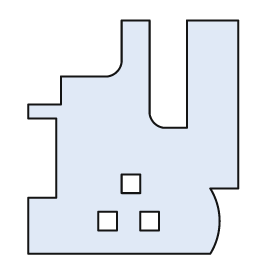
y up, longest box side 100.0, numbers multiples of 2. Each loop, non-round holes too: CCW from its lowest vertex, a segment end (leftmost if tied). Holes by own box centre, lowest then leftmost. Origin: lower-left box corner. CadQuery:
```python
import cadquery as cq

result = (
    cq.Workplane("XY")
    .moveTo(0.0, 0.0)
    .lineTo(78.0, 0.0)
    .threePointArc((82.0, 14.0), (78.0, 28.0))
    .lineTo(90.0, 28.0)
    .lineTo(90.0, 100.0)
    .lineTo(68.0, 100.0)
    .lineTo(68.0, 54.0)
    .lineTo(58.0, 54.0)
    .threePointArc((54.0, 56.0), (52.0, 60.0))
    .lineTo(52.0, 100.0)
    .lineTo(40.0, 100.0)
    .lineTo(40.0, 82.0)
    .threePointArc((38.0, 78.0), (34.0, 76.0))
    .lineTo(14.0, 76.0)
    .lineTo(14.0, 64.0)
    .lineTo(0.0, 64.0)
    .lineTo(0.0, 58.0)
    .lineTo(12.0, 58.0)
    .lineTo(12.0, 24.0)
    .lineTo(0.0, 24.0)
    .close()
    .moveTo(30.0, 10.0)
    .lineTo(38.0, 10.0)
    .lineTo(38.0, 18.0)
    .lineTo(30.0, 18.0)
    .close()
    .moveTo(48.0, 10.0)
    .lineTo(56.0, 10.0)
    .lineTo(56.0, 18.0)
    .lineTo(48.0, 18.0)
    .close()
    .moveTo(40.0, 26.0)
    .lineTo(48.0, 26.0)
    .lineTo(48.0, 34.0)
    .lineTo(40.0, 34.0)
    .close()
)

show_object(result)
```